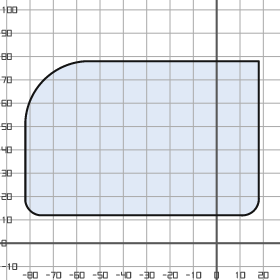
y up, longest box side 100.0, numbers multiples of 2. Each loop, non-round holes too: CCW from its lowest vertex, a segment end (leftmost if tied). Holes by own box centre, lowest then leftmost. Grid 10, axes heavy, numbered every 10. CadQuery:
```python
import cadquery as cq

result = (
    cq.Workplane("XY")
    .moveTo(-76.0, 12.0)
    .lineTo(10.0, 12.0)
    .threePointArc((16.0, 14.0), (18.0, 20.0))
    .lineTo(18.0, 78.0)
    .lineTo(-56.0, 78.0)
    .threePointArc((-74.0, 70.0), (-82.0, 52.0))
    .lineTo(-82.0, 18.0)
    .threePointArc((-80.0, 14.0), (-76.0, 12.0))
    .close()
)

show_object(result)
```